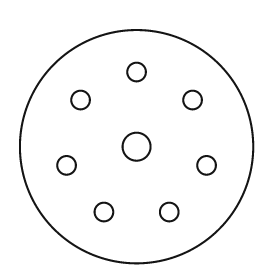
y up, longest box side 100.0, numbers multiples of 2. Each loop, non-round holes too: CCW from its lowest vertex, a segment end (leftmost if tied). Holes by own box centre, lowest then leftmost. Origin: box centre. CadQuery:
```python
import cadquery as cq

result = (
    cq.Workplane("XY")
    .moveTo(0.0, 0.0)
    .circle(50.0)
    .moveTo(-14.0, -28.0)
    .circle(4.0)
    .moveTo(14.0, -28.0)
    .circle(4.0)
    .moveTo(-30.0, -8.0)
    .circle(4.0)
    .moveTo(30.0, -8.0)
    .circle(4.0)
    .moveTo(0.0, 0.0)
    .circle(6.0)
    .moveTo(-24.0, 20.0)
    .circle(4.0)
    .moveTo(24.0, 20.0)
    .circle(4.0)
    .moveTo(0.0, 32.0)
    .circle(4.0)
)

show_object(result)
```